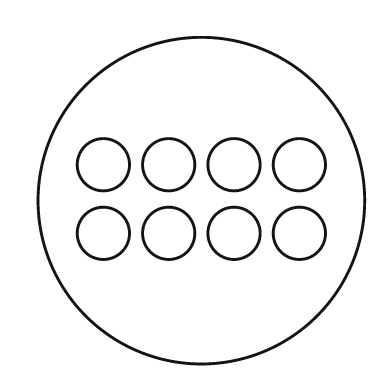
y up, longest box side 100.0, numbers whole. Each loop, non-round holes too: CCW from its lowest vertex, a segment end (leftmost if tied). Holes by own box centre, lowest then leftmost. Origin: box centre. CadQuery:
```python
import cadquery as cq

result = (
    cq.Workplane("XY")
    .moveTo(0.0, 0.0)
    .circle(50.0)
    .moveTo(-30.0, -10.0)
    .circle(8.0)
    .moveTo(-10.0, -10.0)
    .circle(8.0)
    .moveTo(10.0, -10.0)
    .circle(8.0)
    .moveTo(30.0, -10.0)
    .circle(8.0)
    .moveTo(-30.0, 11.0)
    .circle(8.0)
    .moveTo(-10.0, 11.0)
    .circle(8.0)
    .moveTo(10.0, 11.0)
    .circle(8.0)
    .moveTo(30.0, 11.0)
    .circle(8.0)
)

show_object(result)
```